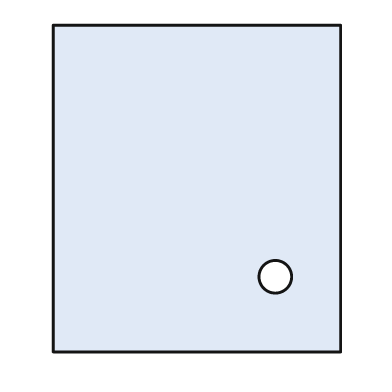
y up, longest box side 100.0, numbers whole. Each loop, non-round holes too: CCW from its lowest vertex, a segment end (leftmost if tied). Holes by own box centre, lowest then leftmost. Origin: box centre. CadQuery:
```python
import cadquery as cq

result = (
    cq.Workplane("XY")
    .moveTo(-44.0, -50.0)
    .lineTo(44.0, -50.0)
    .lineTo(44.0, 50.0)
    .lineTo(-44.0, 50.0)
    .close()
    .moveTo(24.0, -27.0)
    .circle(5.0)
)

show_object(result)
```